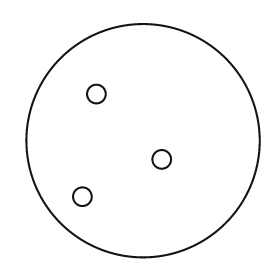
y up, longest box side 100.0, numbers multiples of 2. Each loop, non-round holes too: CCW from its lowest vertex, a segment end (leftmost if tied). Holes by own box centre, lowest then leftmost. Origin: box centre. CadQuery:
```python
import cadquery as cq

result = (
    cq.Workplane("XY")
    .moveTo(0.0, 0.0)
    .circle(50.0)
    .moveTo(-26.0, -24.0)
    .circle(4.0)
    .moveTo(8.0, -8.0)
    .circle(4.0)
    .moveTo(-20.0, 20.0)
    .circle(4.0)
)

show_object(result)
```